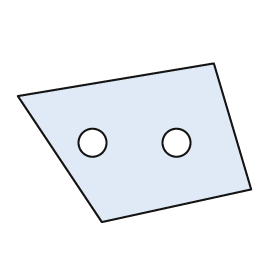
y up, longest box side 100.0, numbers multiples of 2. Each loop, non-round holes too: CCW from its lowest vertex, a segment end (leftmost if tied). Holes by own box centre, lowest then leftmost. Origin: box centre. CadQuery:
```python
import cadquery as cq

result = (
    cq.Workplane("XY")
    .moveTo(-14.0, -34.0)
    .lineTo(50.0, -20.0)
    .lineTo(34.0, 34.0)
    .lineTo(-50.0, 20.0)
    .close()
    .moveTo(-18.0, 0.0)
    .circle(6.0)
    .moveTo(18.0, 0.0)
    .circle(6.0)
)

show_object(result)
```